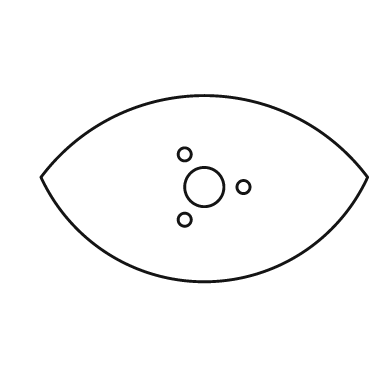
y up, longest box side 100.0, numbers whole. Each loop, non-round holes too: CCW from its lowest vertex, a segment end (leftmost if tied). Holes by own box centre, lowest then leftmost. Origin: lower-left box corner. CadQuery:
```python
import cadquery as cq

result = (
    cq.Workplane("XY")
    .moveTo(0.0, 32.0)
    .threePointArc((50.0, 0.0), (100.0, 32.0))
    .threePointArc((50.0, 57.0), (0.0, 32.0))
    .close()
    .moveTo(44.0, 19.0)
    .circle(2.0)
    .moveTo(50.0, 29.0)
    .circle(6.0)
    .moveTo(62.0, 29.0)
    .circle(2.0)
    .moveTo(44.0, 39.0)
    .circle(2.0)
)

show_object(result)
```